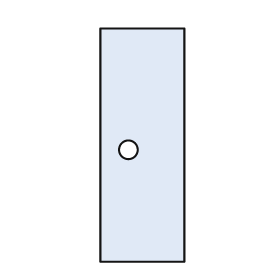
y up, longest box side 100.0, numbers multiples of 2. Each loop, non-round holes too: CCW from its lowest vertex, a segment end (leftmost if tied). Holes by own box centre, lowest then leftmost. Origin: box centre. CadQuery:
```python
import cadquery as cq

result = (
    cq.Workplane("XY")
    .moveTo(-18.0, -50.0)
    .lineTo(18.0, -50.0)
    .lineTo(18.0, 50.0)
    .lineTo(-18.0, 50.0)
    .close()
    .moveTo(-6.0, -2.0)
    .circle(4.0)
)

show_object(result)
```